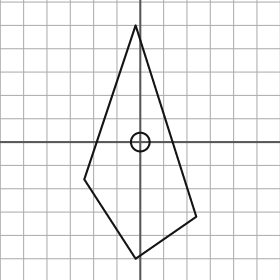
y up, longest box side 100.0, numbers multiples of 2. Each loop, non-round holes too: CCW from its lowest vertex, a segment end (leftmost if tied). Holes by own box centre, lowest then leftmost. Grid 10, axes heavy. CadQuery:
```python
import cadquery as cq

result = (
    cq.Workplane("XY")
    .moveTo(-2.0, -50.0)
    .lineTo(24.0, -32.0)
    .lineTo(-2.0, 50.0)
    .lineTo(-24.0, -16.0)
    .close()
    .moveTo(0.0, 0.0)
    .circle(4.0)
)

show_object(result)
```